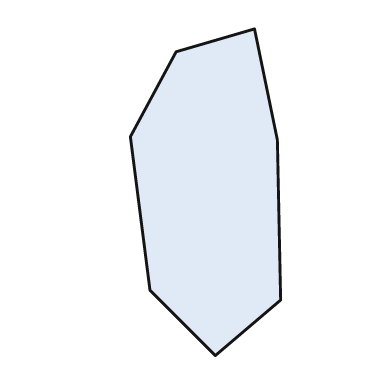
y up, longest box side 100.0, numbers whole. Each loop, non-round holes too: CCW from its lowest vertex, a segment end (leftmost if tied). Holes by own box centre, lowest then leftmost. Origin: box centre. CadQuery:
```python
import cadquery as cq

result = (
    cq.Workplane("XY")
    .moveTo(3.0, -50.0)
    .lineTo(23.0, -33.0)
    .lineTo(22.0, 16.0)
    .lineTo(15.0, 50.0)
    .lineTo(-9.0, 43.0)
    .lineTo(-23.0, 17.0)
    .lineTo(-17.0, -30.0)
    .close()
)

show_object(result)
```